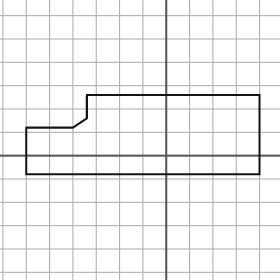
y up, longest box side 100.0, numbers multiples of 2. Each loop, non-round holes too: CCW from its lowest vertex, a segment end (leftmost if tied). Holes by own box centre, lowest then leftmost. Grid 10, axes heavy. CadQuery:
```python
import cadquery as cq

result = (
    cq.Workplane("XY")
    .moveTo(-60.0, -8.0)
    .lineTo(40.0, -8.0)
    .lineTo(40.0, 26.0)
    .lineTo(-34.0, 26.0)
    .lineTo(-34.0, 16.0)
    .lineTo(-40.0, 12.0)
    .lineTo(-60.0, 12.0)
    .close()
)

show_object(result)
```